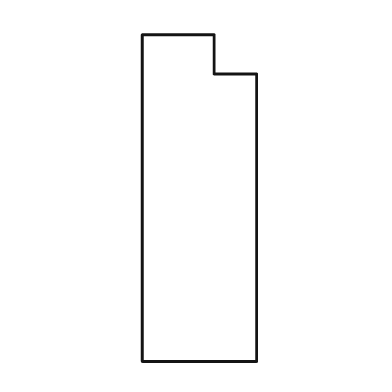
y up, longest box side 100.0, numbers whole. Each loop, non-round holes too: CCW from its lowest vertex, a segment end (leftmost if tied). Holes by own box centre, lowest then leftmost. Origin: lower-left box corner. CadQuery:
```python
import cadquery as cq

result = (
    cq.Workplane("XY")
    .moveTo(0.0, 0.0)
    .lineTo(35.0, 0.0)
    .lineTo(35.0, 88.0)
    .lineTo(22.0, 88.0)
    .lineTo(22.0, 100.0)
    .lineTo(0.0, 100.0)
    .close()
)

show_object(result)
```